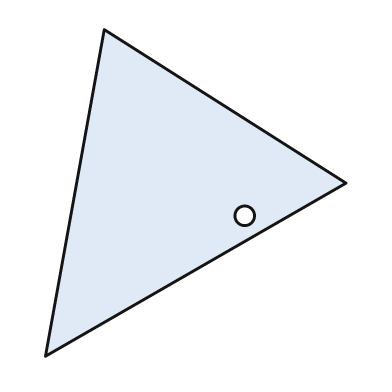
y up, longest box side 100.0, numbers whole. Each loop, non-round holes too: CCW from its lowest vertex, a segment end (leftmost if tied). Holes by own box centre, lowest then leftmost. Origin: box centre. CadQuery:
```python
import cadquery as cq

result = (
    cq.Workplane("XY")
    .moveTo(-46.0, -50.0)
    .lineTo(46.0, 3.0)
    .lineTo(-28.0, 50.0)
    .close()
    .moveTo(15.0, -7.0)
    .circle(3.0)
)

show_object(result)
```